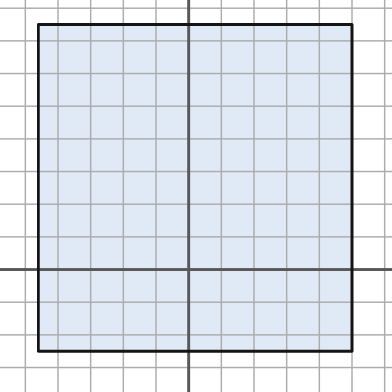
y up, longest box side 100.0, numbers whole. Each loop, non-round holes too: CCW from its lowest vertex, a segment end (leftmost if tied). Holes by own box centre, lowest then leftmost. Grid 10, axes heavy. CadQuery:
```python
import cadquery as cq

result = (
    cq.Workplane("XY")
    .moveTo(-46.0, -25.0)
    .lineTo(50.0, -25.0)
    .lineTo(50.0, 75.0)
    .lineTo(-46.0, 75.0)
    .close()
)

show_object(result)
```